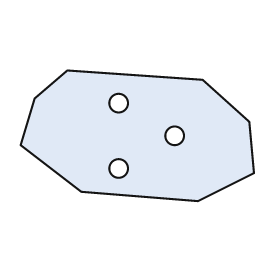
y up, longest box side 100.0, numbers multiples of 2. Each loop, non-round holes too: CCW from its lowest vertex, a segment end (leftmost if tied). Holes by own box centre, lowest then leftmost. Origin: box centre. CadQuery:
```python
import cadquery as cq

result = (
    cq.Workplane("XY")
    .moveTo(26.0, -28.0)
    .lineTo(50.0, -16.0)
    .lineTo(48.0, 6.0)
    .lineTo(28.0, 24.0)
    .lineTo(-30.0, 28.0)
    .lineTo(-44.0, 16.0)
    .lineTo(-50.0, -4.0)
    .lineTo(-24.0, -24.0)
    .close()
    .moveTo(-8.0, -14.0)
    .circle(4.0)
    .moveTo(16.0, 0.0)
    .circle(4.0)
    .moveTo(-8.0, 14.0)
    .circle(4.0)
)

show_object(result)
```